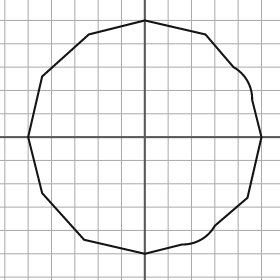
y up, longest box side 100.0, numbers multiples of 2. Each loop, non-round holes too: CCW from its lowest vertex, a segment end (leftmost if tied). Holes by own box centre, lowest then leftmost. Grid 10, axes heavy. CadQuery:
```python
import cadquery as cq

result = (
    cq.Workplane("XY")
    .moveTo(0.0, -50.0)
    .lineTo(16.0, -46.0)
    .threePointArc((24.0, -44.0), (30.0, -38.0))
    .lineTo(44.0, -26.0)
    .lineTo(50.0, 0.0)
    .lineTo(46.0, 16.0)
    .threePointArc((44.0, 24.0), (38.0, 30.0))
    .lineTo(26.0, 44.0)
    .lineTo(0.0, 50.0)
    .lineTo(-24.0, 44.0)
    .lineTo(-44.0, 26.0)
    .lineTo(-50.0, 0.0)
    .lineTo(-44.0, -24.0)
    .lineTo(-26.0, -44.0)
    .close()
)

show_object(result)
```